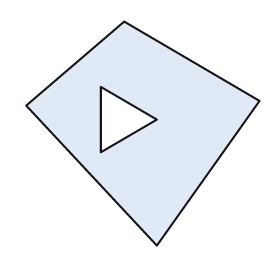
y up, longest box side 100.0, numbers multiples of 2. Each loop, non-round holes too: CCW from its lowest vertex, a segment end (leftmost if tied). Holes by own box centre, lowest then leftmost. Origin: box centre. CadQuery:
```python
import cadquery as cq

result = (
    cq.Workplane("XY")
    .moveTo(6.0, -48.0)
    .lineTo(50.0, 14.0)
    .lineTo(-8.0, 48.0)
    .lineTo(-50.0, 12.0)
    .close()
    .moveTo(-18.0, -8.0)
    .lineTo(6.0, 6.0)
    .lineTo(-18.0, 20.0)
    .close()
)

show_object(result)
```